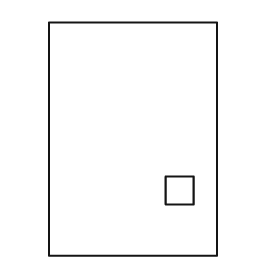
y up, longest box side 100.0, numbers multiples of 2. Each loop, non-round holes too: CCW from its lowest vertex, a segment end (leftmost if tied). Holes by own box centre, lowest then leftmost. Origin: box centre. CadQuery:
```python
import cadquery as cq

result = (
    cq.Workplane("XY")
    .moveTo(-36.0, -50.0)
    .lineTo(36.0, -50.0)
    .lineTo(36.0, 50.0)
    .lineTo(-36.0, 50.0)
    .close()
    .moveTo(14.0, -28.0)
    .lineTo(26.0, -28.0)
    .lineTo(26.0, -16.0)
    .lineTo(14.0, -16.0)
    .close()
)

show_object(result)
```